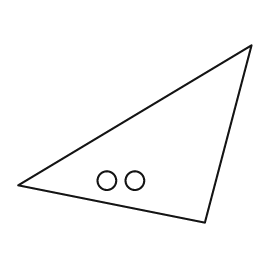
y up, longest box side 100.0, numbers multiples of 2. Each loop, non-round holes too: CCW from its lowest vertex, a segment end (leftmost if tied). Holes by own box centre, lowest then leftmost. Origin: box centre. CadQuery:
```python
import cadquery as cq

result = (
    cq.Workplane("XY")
    .moveTo(30.0, -38.0)
    .lineTo(50.0, 38.0)
    .lineTo(-50.0, -22.0)
    .close()
    .moveTo(-12.0, -20.0)
    .circle(4.0)
    .moveTo(0.0, -20.0)
    .circle(4.0)
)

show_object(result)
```